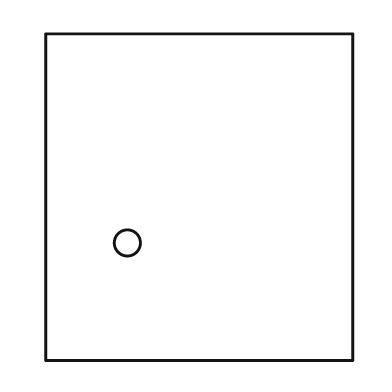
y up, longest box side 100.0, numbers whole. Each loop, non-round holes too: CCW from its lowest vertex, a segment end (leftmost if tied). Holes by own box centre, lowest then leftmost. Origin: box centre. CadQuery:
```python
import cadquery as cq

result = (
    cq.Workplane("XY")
    .moveTo(-47.0, -50.0)
    .lineTo(47.0, -50.0)
    .lineTo(47.0, 50.0)
    .lineTo(-47.0, 50.0)
    .close()
    .moveTo(-22.0, -14.0)
    .circle(4.0)
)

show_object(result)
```